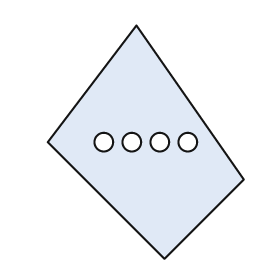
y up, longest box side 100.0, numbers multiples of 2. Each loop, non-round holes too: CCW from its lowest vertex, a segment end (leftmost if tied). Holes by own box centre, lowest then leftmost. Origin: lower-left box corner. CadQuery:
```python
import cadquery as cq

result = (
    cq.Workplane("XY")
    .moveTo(50.0, 0.0)
    .lineTo(84.0, 34.0)
    .lineTo(38.0, 100.0)
    .lineTo(0.0, 50.0)
    .close()
    .moveTo(24.0, 50.0)
    .circle(4.0)
    .moveTo(36.0, 50.0)
    .circle(4.0)
    .moveTo(48.0, 50.0)
    .circle(4.0)
    .moveTo(60.0, 50.0)
    .circle(4.0)
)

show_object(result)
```